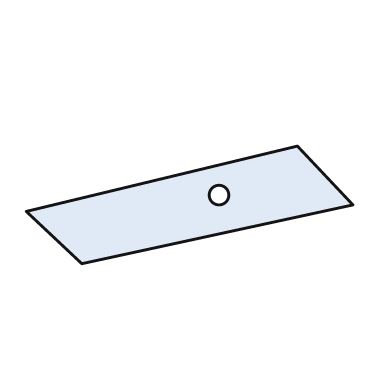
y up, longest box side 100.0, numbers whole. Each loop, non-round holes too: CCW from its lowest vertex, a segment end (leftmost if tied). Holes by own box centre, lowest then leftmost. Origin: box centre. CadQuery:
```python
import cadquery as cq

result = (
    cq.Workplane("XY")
    .moveTo(-33.0, -18.0)
    .lineTo(50.0, 0.0)
    .lineTo(33.0, 18.0)
    .lineTo(-50.0, -2.0)
    .close()
    .moveTo(9.0, 3.0)
    .circle(3.0)
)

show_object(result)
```